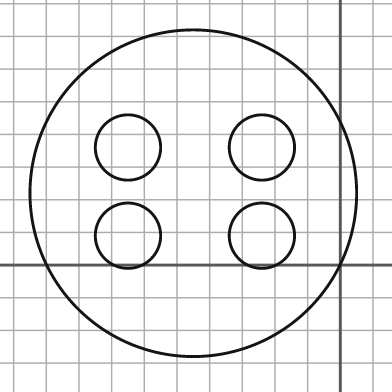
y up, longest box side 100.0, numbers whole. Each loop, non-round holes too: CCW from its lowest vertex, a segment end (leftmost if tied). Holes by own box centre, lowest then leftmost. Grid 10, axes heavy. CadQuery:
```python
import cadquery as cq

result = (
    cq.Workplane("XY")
    .moveTo(-45.0, 22.0)
    .circle(50.0)
    .moveTo(-65.0, 9.0)
    .circle(10.0)
    .moveTo(-24.0, 9.0)
    .circle(10.0)
    .moveTo(-65.0, 36.0)
    .circle(10.0)
    .moveTo(-24.0, 36.0)
    .circle(10.0)
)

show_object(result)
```